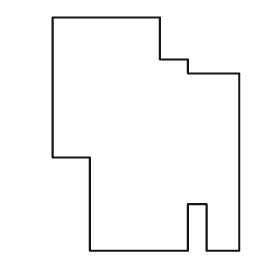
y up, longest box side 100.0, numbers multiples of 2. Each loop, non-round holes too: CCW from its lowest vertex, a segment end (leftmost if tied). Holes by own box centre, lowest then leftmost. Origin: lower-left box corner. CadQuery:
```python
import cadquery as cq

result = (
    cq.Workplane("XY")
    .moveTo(16.0, 0.0)
    .lineTo(58.0, 0.0)
    .lineTo(58.0, 20.0)
    .lineTo(66.0, 20.0)
    .lineTo(66.0, 0.0)
    .lineTo(80.0, 0.0)
    .lineTo(80.0, 76.0)
    .lineTo(58.0, 76.0)
    .lineTo(58.0, 82.0)
    .lineTo(46.0, 82.0)
    .lineTo(46.0, 100.0)
    .lineTo(0.0, 100.0)
    .lineTo(0.0, 40.0)
    .lineTo(16.0, 40.0)
    .close()
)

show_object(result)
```